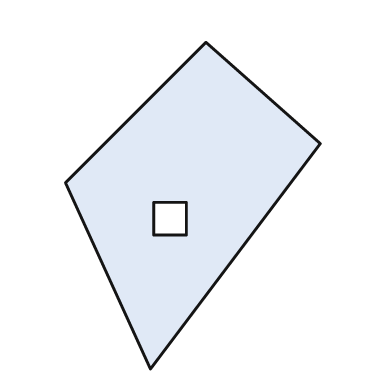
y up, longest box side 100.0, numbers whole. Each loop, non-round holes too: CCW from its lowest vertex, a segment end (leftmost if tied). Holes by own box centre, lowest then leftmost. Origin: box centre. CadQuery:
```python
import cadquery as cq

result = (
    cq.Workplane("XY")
    .moveTo(-13.0, -50.0)
    .lineTo(39.0, 19.0)
    .lineTo(4.0, 50.0)
    .lineTo(-39.0, 7.0)
    .close()
    .moveTo(-12.0, -9.0)
    .lineTo(-2.0, -9.0)
    .lineTo(-2.0, 1.0)
    .lineTo(-12.0, 1.0)
    .close()
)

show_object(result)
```